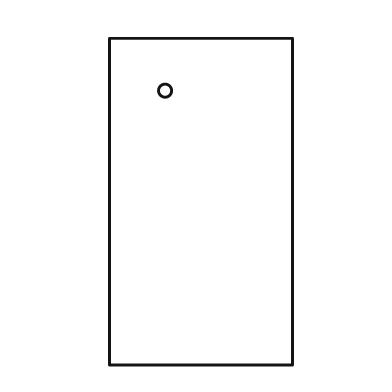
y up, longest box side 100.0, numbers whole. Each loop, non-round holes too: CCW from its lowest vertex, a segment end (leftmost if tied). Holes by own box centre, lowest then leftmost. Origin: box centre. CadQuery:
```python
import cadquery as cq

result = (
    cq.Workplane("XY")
    .moveTo(-28.0, -50.0)
    .lineTo(28.0, -50.0)
    .lineTo(28.0, 50.0)
    .lineTo(-28.0, 50.0)
    .close()
    .moveTo(-11.0, 34.0)
    .circle(2.0)
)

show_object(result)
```